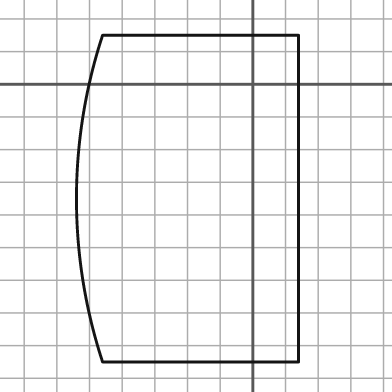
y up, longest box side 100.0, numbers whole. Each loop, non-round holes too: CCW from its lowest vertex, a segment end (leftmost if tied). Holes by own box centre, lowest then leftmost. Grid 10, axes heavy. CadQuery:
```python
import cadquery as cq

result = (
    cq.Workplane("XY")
    .moveTo(-46.0, -85.0)
    .lineTo(14.0, -85.0)
    .lineTo(14.0, 15.0)
    .lineTo(-46.0, 15.0)
    .threePointArc((-54.0, -35.0), (-46.0, -85.0))
    .close()
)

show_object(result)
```